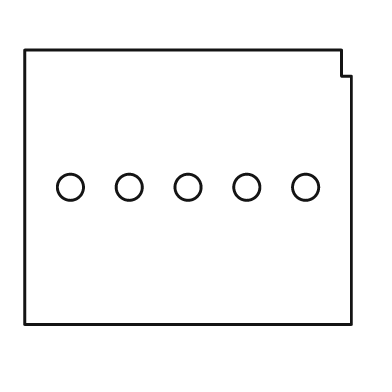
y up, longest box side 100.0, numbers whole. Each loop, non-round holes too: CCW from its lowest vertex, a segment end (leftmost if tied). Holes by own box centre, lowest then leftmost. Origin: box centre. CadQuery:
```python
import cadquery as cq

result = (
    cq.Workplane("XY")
    .moveTo(-50.0, -42.0)
    .lineTo(50.0, -42.0)
    .lineTo(50.0, 34.0)
    .lineTo(47.0, 34.0)
    .lineTo(47.0, 42.0)
    .lineTo(-50.0, 42.0)
    .close()
    .moveTo(-36.0, 0.0)
    .circle(4.0)
    .moveTo(-18.0, 0.0)
    .circle(4.0)
    .moveTo(0.0, 0.0)
    .circle(4.0)
    .moveTo(18.0, 0.0)
    .circle(4.0)
    .moveTo(36.0, 0.0)
    .circle(4.0)
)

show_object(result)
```